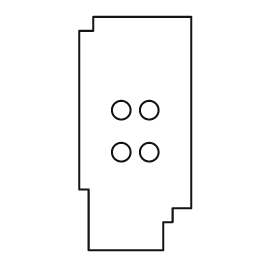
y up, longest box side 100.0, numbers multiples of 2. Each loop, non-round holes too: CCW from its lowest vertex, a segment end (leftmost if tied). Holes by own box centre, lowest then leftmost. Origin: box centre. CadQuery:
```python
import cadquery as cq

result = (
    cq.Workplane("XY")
    .moveTo(-20.0, -50.0)
    .lineTo(12.0, -50.0)
    .lineTo(12.0, -38.0)
    .lineTo(16.0, -38.0)
    .lineTo(16.0, -32.0)
    .lineTo(24.0, -32.0)
    .lineTo(24.0, 50.0)
    .lineTo(-18.0, 50.0)
    .lineTo(-18.0, 44.0)
    .lineTo(-24.0, 44.0)
    .lineTo(-24.0, -24.0)
    .lineTo(-20.0, -24.0)
    .close()
    .moveTo(-6.0, -8.0)
    .circle(4.0)
    .moveTo(6.0, -8.0)
    .circle(4.0)
    .moveTo(-6.0, 10.0)
    .circle(4.0)
    .moveTo(6.0, 10.0)
    .circle(4.0)
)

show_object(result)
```